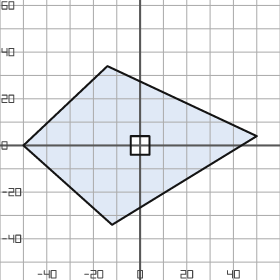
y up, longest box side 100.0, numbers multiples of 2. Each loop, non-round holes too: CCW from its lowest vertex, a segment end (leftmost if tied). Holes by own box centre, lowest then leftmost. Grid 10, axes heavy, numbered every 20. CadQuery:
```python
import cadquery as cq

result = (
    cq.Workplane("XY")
    .moveTo(-12.0, -34.0)
    .lineTo(50.0, 4.0)
    .lineTo(-14.0, 34.0)
    .lineTo(-50.0, 0.0)
    .close()
    .moveTo(-4.0, -4.0)
    .lineTo(4.0, -4.0)
    .lineTo(4.0, 4.0)
    .lineTo(-4.0, 4.0)
    .close()
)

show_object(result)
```